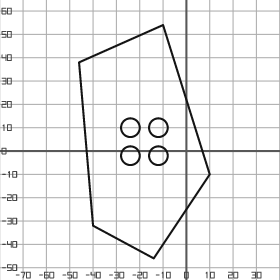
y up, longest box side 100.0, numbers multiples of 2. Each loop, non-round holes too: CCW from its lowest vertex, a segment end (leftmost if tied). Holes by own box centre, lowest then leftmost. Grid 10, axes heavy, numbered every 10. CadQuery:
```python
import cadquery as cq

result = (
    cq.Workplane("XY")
    .moveTo(-14.0, -46.0)
    .lineTo(10.0, -10.0)
    .lineTo(-10.0, 54.0)
    .lineTo(-46.0, 38.0)
    .lineTo(-40.0, -32.0)
    .close()
    .moveTo(-24.0, -2.0)
    .circle(4.0)
    .moveTo(-12.0, -2.0)
    .circle(4.0)
    .moveTo(-24.0, 10.0)
    .circle(4.0)
    .moveTo(-12.0, 10.0)
    .circle(4.0)
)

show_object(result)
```